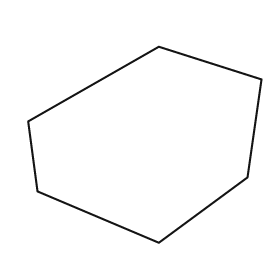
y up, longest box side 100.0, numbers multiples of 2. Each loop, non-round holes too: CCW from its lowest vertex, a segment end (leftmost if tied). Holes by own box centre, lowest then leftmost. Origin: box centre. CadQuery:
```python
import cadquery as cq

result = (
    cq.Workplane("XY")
    .moveTo(6.0, -42.0)
    .lineTo(44.0, -14.0)
    .lineTo(50.0, 28.0)
    .lineTo(6.0, 42.0)
    .lineTo(-50.0, 10.0)
    .lineTo(-46.0, -20.0)
    .close()
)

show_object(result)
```